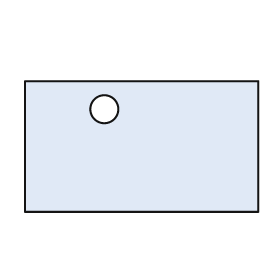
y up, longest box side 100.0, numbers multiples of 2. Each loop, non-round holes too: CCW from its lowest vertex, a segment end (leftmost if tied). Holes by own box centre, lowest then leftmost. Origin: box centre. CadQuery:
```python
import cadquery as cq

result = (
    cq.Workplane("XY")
    .moveTo(-50.0, -28.0)
    .lineTo(50.0, -28.0)
    .lineTo(50.0, 28.0)
    .lineTo(-50.0, 28.0)
    .close()
    .moveTo(-16.0, 16.0)
    .circle(6.0)
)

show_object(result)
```